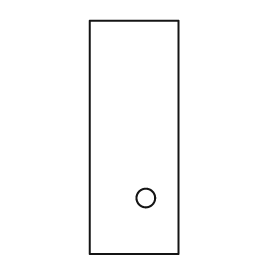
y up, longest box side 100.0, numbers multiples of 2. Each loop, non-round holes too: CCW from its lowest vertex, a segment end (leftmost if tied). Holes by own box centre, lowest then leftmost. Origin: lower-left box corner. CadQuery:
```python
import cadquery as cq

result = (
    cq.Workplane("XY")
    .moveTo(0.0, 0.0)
    .lineTo(38.0, 0.0)
    .lineTo(38.0, 100.0)
    .lineTo(0.0, 100.0)
    .close()
    .moveTo(24.0, 24.0)
    .circle(4.0)
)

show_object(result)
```